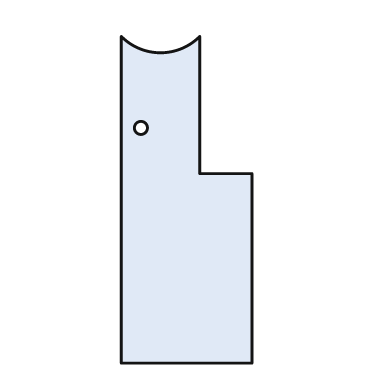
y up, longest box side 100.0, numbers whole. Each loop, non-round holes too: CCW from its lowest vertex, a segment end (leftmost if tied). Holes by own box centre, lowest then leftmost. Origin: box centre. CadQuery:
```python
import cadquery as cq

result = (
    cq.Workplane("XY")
    .moveTo(-20.0, -50.0)
    .lineTo(20.0, -50.0)
    .lineTo(20.0, 8.0)
    .lineTo(4.0, 8.0)
    .lineTo(4.0, 50.0)
    .threePointArc((-8.0, 45.0), (-20.0, 50.0))
    .close()
    .moveTo(-14.0, 22.0)
    .circle(2.0)
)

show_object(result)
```